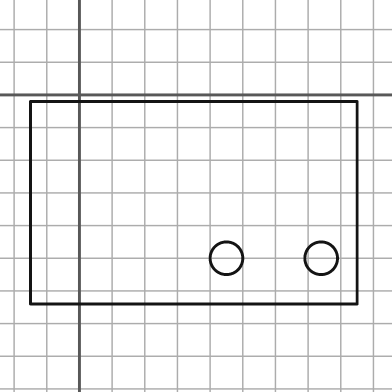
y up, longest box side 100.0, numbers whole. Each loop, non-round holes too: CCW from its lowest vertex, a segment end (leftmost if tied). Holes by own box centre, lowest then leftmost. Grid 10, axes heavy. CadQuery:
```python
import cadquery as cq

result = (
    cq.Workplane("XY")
    .moveTo(-15.0, -64.0)
    .lineTo(85.0, -64.0)
    .lineTo(85.0, -2.0)
    .lineTo(-15.0, -2.0)
    .close()
    .moveTo(45.0, -50.0)
    .circle(5.0)
    .moveTo(74.0, -50.0)
    .circle(5.0)
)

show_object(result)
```